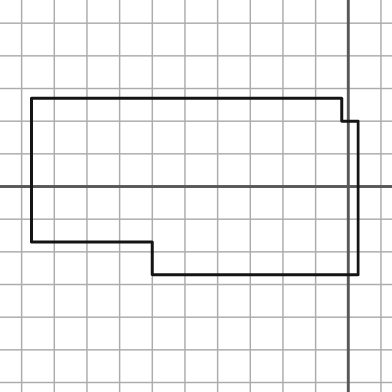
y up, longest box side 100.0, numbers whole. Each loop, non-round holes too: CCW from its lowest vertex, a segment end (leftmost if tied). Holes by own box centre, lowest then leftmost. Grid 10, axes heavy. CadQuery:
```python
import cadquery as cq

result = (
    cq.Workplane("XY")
    .moveTo(-60.0, -27.0)
    .lineTo(3.0, -27.0)
    .lineTo(3.0, 20.0)
    .lineTo(-2.0, 20.0)
    .lineTo(-2.0, 27.0)
    .lineTo(-97.0, 27.0)
    .lineTo(-97.0, -17.0)
    .lineTo(-60.0, -17.0)
    .close()
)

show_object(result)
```